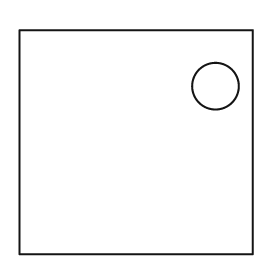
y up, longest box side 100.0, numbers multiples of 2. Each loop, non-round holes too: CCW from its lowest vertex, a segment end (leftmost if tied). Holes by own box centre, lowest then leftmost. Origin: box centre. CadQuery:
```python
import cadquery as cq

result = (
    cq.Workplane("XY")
    .moveTo(-50.0, -48.0)
    .lineTo(50.0, -48.0)
    .lineTo(50.0, 48.0)
    .lineTo(-50.0, 48.0)
    .close()
    .moveTo(34.0, 24.0)
    .circle(10.0)
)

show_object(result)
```